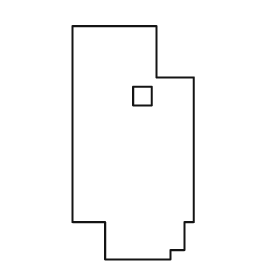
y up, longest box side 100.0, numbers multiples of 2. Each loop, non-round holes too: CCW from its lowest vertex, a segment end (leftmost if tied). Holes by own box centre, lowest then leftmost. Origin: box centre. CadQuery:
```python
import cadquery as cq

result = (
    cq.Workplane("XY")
    .moveTo(-12.0, -50.0)
    .lineTo(16.0, -50.0)
    .lineTo(16.0, -46.0)
    .lineTo(22.0, -46.0)
    .lineTo(22.0, -34.0)
    .lineTo(26.0, -34.0)
    .lineTo(26.0, 28.0)
    .lineTo(10.0, 28.0)
    .lineTo(10.0, 50.0)
    .lineTo(-26.0, 50.0)
    .lineTo(-26.0, -34.0)
    .lineTo(-12.0, -34.0)
    .close()
    .moveTo(0.0, 16.0)
    .lineTo(8.0, 16.0)
    .lineTo(8.0, 24.0)
    .lineTo(0.0, 24.0)
    .close()
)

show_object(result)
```